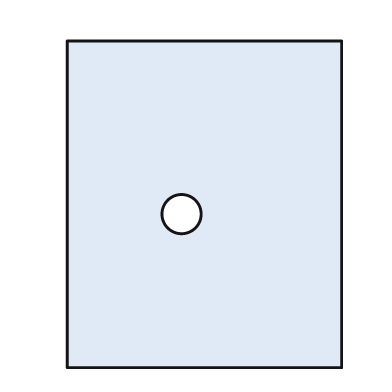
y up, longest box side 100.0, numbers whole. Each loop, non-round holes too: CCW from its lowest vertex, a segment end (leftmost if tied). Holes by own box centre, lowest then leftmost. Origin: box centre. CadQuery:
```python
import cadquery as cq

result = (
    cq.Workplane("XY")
    .moveTo(-42.0, -50.0)
    .lineTo(42.0, -50.0)
    .lineTo(42.0, 50.0)
    .lineTo(-42.0, 50.0)
    .close()
    .moveTo(-7.0, -3.0)
    .circle(6.0)
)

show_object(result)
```